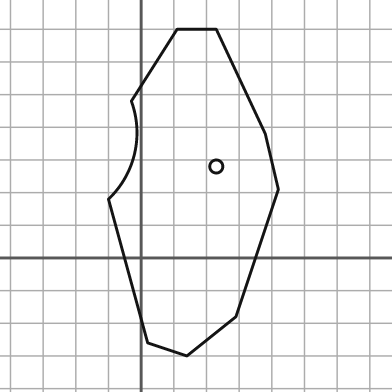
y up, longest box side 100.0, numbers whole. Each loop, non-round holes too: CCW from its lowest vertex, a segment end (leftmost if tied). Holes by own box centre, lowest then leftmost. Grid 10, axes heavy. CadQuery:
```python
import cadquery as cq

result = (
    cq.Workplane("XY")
    .moveTo(14.0, -30.0)
    .lineTo(29.0, -18.0)
    .lineTo(42.0, 21.0)
    .lineTo(38.0, 38.0)
    .lineTo(23.0, 70.0)
    .lineTo(11.0, 70.0)
    .lineTo(-3.0, 48.0)
    .threePointArc((-2.0, 32.0), (-10.0, 18.0))
    .lineTo(2.0, -26.0)
    .close()
    .moveTo(23.0, 28.0)
    .circle(2.0)
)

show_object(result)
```